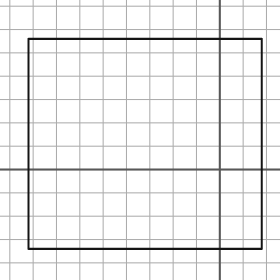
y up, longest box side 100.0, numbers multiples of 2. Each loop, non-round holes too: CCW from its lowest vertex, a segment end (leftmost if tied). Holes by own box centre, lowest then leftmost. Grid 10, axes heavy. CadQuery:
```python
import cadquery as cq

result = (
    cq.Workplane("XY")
    .moveTo(-82.0, -34.0)
    .lineTo(18.0, -34.0)
    .lineTo(18.0, 56.0)
    .lineTo(-82.0, 56.0)
    .close()
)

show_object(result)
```